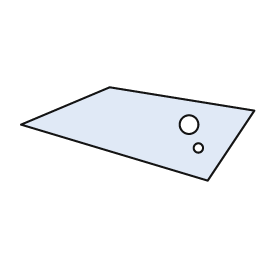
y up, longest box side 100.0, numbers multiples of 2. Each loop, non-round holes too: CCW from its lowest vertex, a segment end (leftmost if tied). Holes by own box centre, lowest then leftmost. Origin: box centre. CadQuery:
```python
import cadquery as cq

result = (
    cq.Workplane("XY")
    .moveTo(30.0, -20.0)
    .lineTo(50.0, 10.0)
    .lineTo(-12.0, 20.0)
    .lineTo(-50.0, 4.0)
    .close()
    .moveTo(26.0, -6.0)
    .circle(2.0)
    .moveTo(22.0, 4.0)
    .circle(4.0)
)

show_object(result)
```